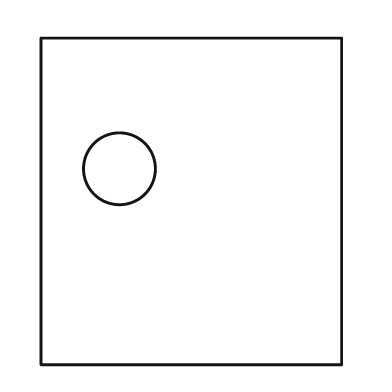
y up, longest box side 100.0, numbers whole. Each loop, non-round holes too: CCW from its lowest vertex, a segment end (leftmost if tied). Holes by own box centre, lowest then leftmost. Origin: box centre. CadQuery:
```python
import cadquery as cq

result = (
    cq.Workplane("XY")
    .moveTo(-46.0, -50.0)
    .lineTo(46.0, -50.0)
    .lineTo(46.0, 50.0)
    .lineTo(-46.0, 50.0)
    .close()
    .moveTo(-22.0, 10.0)
    .circle(11.0)
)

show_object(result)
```